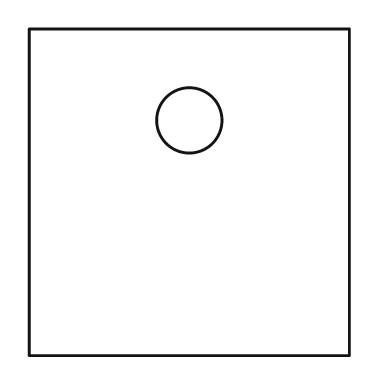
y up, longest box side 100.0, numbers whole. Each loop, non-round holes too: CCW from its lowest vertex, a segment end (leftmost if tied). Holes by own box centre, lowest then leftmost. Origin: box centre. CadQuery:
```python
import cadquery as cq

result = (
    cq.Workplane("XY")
    .moveTo(-49.0, -50.0)
    .lineTo(49.0, -50.0)
    .lineTo(49.0, 50.0)
    .lineTo(-49.0, 50.0)
    .close()
    .moveTo(0.0, 22.0)
    .circle(10.0)
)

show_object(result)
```